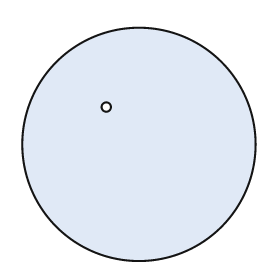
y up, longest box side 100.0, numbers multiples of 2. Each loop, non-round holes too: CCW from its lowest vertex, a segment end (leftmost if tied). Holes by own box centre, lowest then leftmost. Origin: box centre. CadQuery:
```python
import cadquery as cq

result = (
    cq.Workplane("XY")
    .moveTo(0.0, 0.0)
    .circle(50.0)
    .moveTo(-14.0, 16.0)
    .circle(2.0)
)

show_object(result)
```